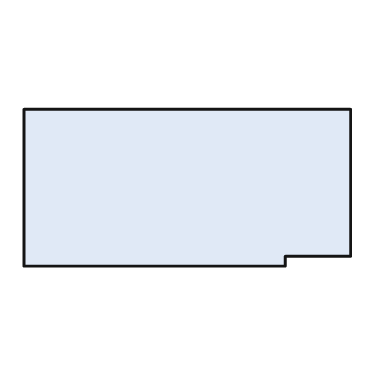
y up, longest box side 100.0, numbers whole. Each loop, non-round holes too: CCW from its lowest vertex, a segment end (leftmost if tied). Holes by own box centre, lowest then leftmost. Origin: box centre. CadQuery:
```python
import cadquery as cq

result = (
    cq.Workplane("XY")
    .moveTo(-50.0, -24.0)
    .lineTo(30.0, -24.0)
    .lineTo(30.0, -21.0)
    .lineTo(50.0, -21.0)
    .lineTo(50.0, 24.0)
    .lineTo(-50.0, 24.0)
    .close()
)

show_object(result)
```